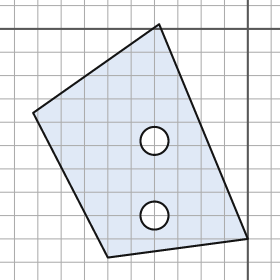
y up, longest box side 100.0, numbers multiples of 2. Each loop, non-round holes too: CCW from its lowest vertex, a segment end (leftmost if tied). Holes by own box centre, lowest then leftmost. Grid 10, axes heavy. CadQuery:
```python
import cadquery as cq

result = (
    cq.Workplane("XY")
    .moveTo(-60.0, -98.0)
    .lineTo(0.0, -90.0)
    .lineTo(-38.0, 2.0)
    .lineTo(-92.0, -36.0)
    .close()
    .moveTo(-40.0, -80.0)
    .circle(6.0)
    .moveTo(-40.0, -48.0)
    .circle(6.0)
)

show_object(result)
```